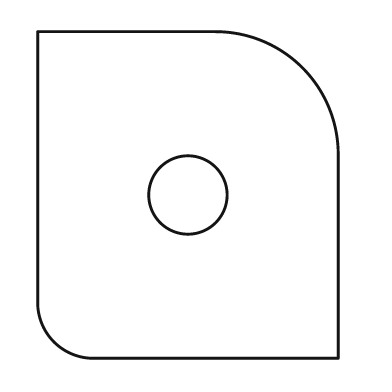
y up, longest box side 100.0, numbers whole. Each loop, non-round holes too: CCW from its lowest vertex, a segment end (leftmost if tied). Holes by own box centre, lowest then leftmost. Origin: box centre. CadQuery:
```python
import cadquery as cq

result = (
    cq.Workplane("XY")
    .moveTo(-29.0, -50.0)
    .lineTo(46.0, -50.0)
    .lineTo(46.0, 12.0)
    .threePointArc((35.0, 39.0), (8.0, 50.0))
    .lineTo(-46.0, 50.0)
    .lineTo(-46.0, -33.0)
    .threePointArc((-41.0, -45.0), (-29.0, -50.0))
    .close()
    .moveTo(0.0, 0.0)
    .circle(12.0)
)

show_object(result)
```